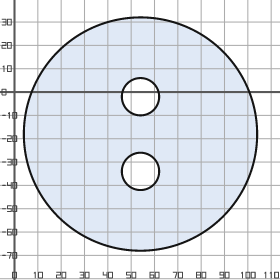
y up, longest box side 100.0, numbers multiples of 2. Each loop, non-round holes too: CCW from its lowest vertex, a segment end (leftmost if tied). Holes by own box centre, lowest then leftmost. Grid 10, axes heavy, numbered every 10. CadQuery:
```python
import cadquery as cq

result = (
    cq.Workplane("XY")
    .moveTo(54.0, -18.0)
    .circle(50.0)
    .moveTo(54.0, -34.0)
    .circle(8.0)
    .moveTo(54.0, -2.0)
    .circle(8.0)
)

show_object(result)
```